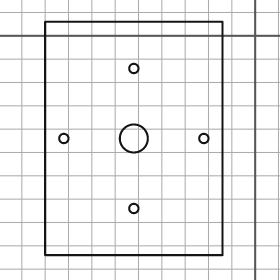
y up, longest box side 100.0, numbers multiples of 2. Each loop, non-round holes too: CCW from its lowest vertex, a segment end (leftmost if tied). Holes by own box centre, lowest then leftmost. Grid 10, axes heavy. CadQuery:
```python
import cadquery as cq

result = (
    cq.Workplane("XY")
    .moveTo(-90.0, -94.0)
    .lineTo(-14.0, -94.0)
    .lineTo(-14.0, 6.0)
    .lineTo(-90.0, 6.0)
    .close()
    .moveTo(-52.0, -74.0)
    .circle(2.0)
    .moveTo(-82.0, -44.0)
    .circle(2.0)
    .moveTo(-52.0, -44.0)
    .circle(6.0)
    .moveTo(-22.0, -44.0)
    .circle(2.0)
    .moveTo(-52.0, -14.0)
    .circle(2.0)
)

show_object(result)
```